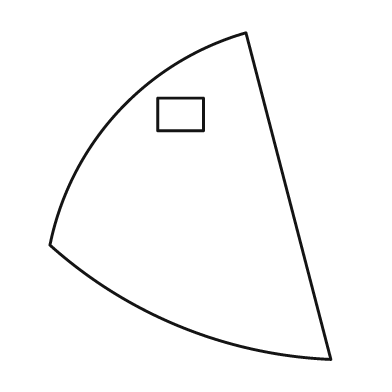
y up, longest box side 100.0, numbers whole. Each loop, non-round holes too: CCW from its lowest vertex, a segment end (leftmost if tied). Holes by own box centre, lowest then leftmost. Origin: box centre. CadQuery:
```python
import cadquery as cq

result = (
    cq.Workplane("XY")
    .moveTo(43.0, -50.0)
    .lineTo(17.0, 50.0)
    .threePointArc((-22.0, 26.0), (-43.0, -15.0))
    .threePointArc((-3.0, -40.0), (43.0, -50.0))
    .close()
    .moveTo(-10.0, 20.0)
    .lineTo(4.0, 20.0)
    .lineTo(4.0, 30.0)
    .lineTo(-10.0, 30.0)
    .close()
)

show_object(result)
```